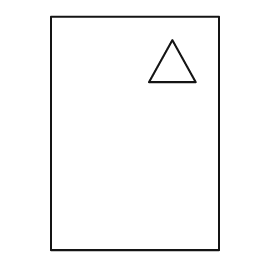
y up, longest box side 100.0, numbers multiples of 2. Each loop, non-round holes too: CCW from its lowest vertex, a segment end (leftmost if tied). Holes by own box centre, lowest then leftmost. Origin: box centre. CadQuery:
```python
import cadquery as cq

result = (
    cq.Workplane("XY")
    .moveTo(-36.0, -50.0)
    .lineTo(36.0, -50.0)
    .lineTo(36.0, 50.0)
    .lineTo(-36.0, 50.0)
    .close()
    .moveTo(6.0, 22.0)
    .lineTo(26.0, 22.0)
    .lineTo(16.0, 40.0)
    .close()
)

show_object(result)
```